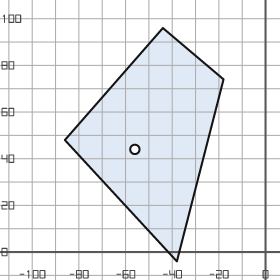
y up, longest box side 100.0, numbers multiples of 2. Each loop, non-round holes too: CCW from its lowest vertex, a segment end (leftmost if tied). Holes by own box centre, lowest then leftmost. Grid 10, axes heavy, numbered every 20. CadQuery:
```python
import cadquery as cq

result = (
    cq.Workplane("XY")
    .moveTo(-38.0, -4.0)
    .lineTo(-18.0, 74.0)
    .lineTo(-44.0, 96.0)
    .lineTo(-86.0, 48.0)
    .close()
    .moveTo(-56.0, 44.0)
    .circle(2.0)
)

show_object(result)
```